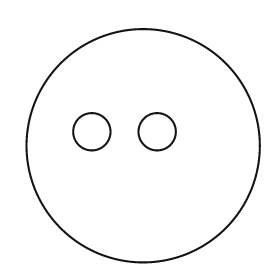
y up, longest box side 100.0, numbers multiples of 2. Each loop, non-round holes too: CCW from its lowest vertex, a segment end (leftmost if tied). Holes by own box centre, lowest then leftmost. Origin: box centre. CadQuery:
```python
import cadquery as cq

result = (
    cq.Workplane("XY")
    .moveTo(0.0, 0.0)
    .circle(50.0)
    .moveTo(-22.0, 6.0)
    .circle(8.0)
    .moveTo(6.0, 6.0)
    .circle(8.0)
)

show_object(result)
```